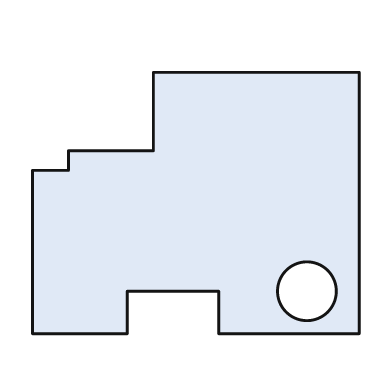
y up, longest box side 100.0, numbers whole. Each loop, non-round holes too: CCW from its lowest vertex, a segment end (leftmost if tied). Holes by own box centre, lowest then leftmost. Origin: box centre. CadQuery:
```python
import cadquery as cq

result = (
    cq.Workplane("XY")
    .moveTo(-50.0, -40.0)
    .lineTo(-21.0, -40.0)
    .lineTo(-21.0, -27.0)
    .lineTo(7.0, -27.0)
    .lineTo(7.0, -40.0)
    .lineTo(50.0, -40.0)
    .lineTo(50.0, 40.0)
    .lineTo(-13.0, 40.0)
    .lineTo(-13.0, 16.0)
    .lineTo(-39.0, 16.0)
    .lineTo(-39.0, 10.0)
    .lineTo(-50.0, 10.0)
    .close()
    .moveTo(34.0, -27.0)
    .circle(9.0)
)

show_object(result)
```